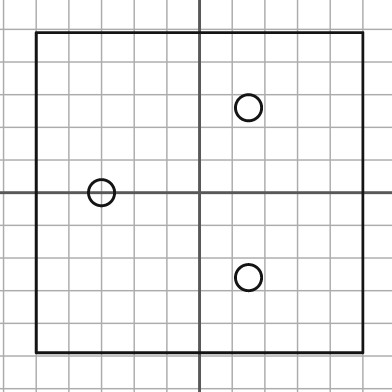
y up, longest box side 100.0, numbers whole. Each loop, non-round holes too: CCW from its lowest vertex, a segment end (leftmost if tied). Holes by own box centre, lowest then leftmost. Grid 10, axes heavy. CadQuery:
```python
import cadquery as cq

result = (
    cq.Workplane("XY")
    .moveTo(-50.0, -49.0)
    .lineTo(50.0, -49.0)
    .lineTo(50.0, 49.0)
    .lineTo(-50.0, 49.0)
    .close()
    .moveTo(15.0, -26.0)
    .circle(4.0)
    .moveTo(-30.0, 0.0)
    .circle(4.0)
    .moveTo(15.0, 26.0)
    .circle(4.0)
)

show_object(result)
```